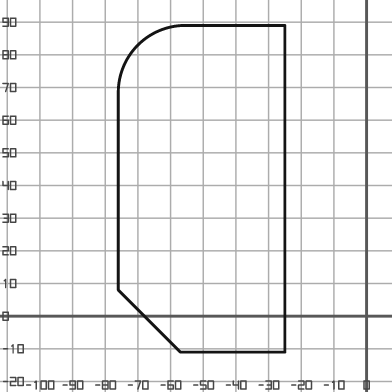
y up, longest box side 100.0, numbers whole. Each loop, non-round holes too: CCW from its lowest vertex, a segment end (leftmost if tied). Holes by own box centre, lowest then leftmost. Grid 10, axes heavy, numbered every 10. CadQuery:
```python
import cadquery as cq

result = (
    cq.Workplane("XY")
    .moveTo(-57.0, -11.0)
    .lineTo(-25.0, -11.0)
    .lineTo(-25.0, 89.0)
    .lineTo(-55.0, 89.0)
    .threePointArc((-70.0, 83.0), (-76.0, 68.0))
    .lineTo(-76.0, 8.0)
    .close()
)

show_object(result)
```